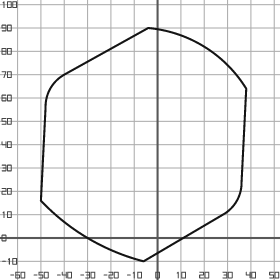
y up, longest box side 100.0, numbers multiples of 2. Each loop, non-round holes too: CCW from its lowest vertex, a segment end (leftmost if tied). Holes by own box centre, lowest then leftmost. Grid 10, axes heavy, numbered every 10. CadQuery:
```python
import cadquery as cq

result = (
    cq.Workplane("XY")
    .moveTo(-6.0, -10.0)
    .lineTo(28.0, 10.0)
    .threePointArc((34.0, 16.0), (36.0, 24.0))
    .lineTo(38.0, 64.0)
    .threePointArc((20.0, 82.0), (-4.0, 90.0))
    .lineTo(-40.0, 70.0)
    .threePointArc((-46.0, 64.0), (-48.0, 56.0))
    .lineTo(-50.0, 16.0)
    .threePointArc((-30.0, 0.0), (-6.0, -10.0))
    .close()
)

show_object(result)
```